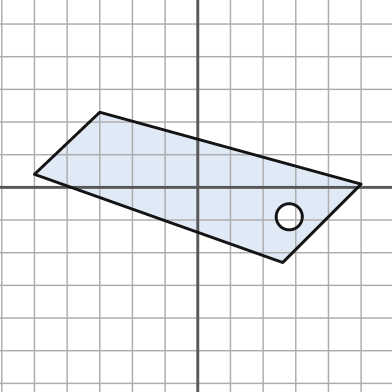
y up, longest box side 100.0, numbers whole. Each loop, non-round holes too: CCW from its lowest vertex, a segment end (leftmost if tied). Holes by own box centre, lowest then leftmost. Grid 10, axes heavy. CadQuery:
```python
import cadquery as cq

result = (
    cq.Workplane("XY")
    .moveTo(26.0, -23.0)
    .lineTo(50.0, 1.0)
    .lineTo(-30.0, 23.0)
    .lineTo(-50.0, 4.0)
    .close()
    .moveTo(28.0, -9.0)
    .circle(4.0)
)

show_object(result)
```